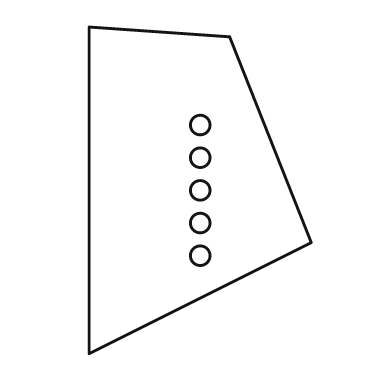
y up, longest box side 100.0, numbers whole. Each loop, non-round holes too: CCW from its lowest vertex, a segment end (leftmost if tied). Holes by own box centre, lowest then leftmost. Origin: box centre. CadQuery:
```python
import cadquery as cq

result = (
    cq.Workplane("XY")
    .moveTo(-34.0, -50.0)
    .lineTo(34.0, -16.0)
    .lineTo(9.0, 47.0)
    .lineTo(-34.0, 50.0)
    .close()
    .moveTo(0.0, -20.0)
    .circle(3.0)
    .moveTo(0.0, -10.0)
    .circle(3.0)
    .moveTo(0.0, 0.0)
    .circle(3.0)
    .moveTo(0.0, 10.0)
    .circle(3.0)
    .moveTo(0.0, 20.0)
    .circle(3.0)
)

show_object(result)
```